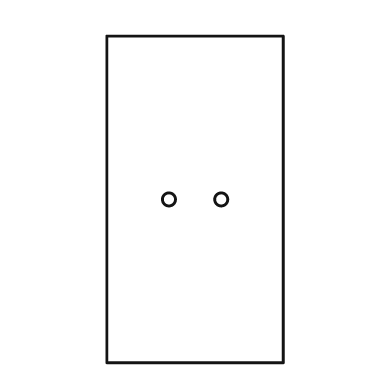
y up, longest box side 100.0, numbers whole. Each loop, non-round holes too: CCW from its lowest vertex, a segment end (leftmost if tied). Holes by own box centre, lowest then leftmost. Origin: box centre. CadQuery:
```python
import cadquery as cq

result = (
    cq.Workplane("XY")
    .moveTo(-27.0, -50.0)
    .lineTo(27.0, -50.0)
    .lineTo(27.0, 50.0)
    .lineTo(-27.0, 50.0)
    .close()
    .moveTo(-8.0, 0.0)
    .circle(2.0)
    .moveTo(8.0, 0.0)
    .circle(2.0)
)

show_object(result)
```